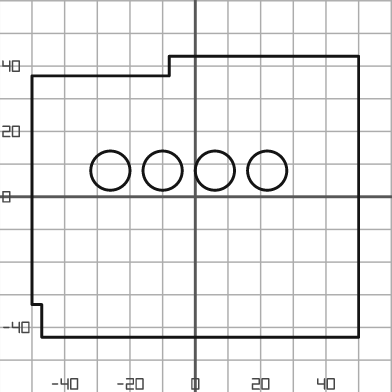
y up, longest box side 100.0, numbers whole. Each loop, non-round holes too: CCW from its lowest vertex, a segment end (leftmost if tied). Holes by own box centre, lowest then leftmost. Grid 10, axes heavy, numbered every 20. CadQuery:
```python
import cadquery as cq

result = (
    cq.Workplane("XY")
    .moveTo(-47.0, -43.0)
    .lineTo(50.0, -43.0)
    .lineTo(50.0, 43.0)
    .lineTo(-8.0, 43.0)
    .lineTo(-8.0, 37.0)
    .lineTo(-50.0, 37.0)
    .lineTo(-50.0, -33.0)
    .lineTo(-47.0, -33.0)
    .close()
    .moveTo(-26.0, 8.0)
    .circle(6.0)
    .moveTo(-10.0, 8.0)
    .circle(6.0)
    .moveTo(6.0, 8.0)
    .circle(6.0)
    .moveTo(22.0, 8.0)
    .circle(6.0)
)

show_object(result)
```